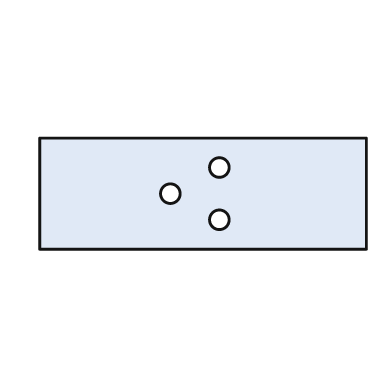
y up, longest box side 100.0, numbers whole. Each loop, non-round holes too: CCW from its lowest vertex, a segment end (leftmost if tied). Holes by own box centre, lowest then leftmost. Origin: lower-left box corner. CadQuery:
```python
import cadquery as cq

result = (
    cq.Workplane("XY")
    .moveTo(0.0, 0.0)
    .lineTo(100.0, 0.0)
    .lineTo(100.0, 34.0)
    .lineTo(0.0, 34.0)
    .close()
    .moveTo(55.0, 9.0)
    .circle(3.0)
    .moveTo(40.0, 17.0)
    .circle(3.0)
    .moveTo(55.0, 25.0)
    .circle(3.0)
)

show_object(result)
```